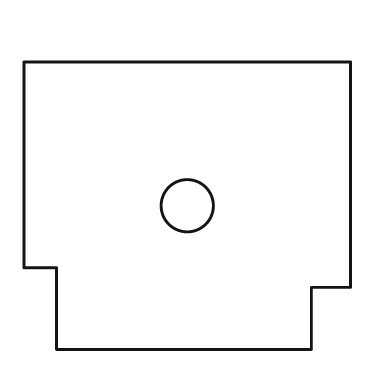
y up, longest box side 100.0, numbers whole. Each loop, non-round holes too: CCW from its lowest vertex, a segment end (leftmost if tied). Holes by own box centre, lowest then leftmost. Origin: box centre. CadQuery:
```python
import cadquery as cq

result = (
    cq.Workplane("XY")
    .moveTo(-40.0, -44.0)
    .lineTo(38.0, -44.0)
    .lineTo(38.0, -25.0)
    .lineTo(50.0, -25.0)
    .lineTo(50.0, 44.0)
    .lineTo(-50.0, 44.0)
    .lineTo(-50.0, -19.0)
    .lineTo(-40.0, -19.0)
    .close()
    .moveTo(0.0, 0.0)
    .circle(8.0)
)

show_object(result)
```